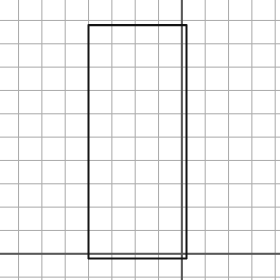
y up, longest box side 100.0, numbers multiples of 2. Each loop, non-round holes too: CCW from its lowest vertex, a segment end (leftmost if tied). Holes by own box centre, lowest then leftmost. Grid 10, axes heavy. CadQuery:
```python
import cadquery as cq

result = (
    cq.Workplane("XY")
    .moveTo(-40.0, -2.0)
    .lineTo(2.0, -2.0)
    .lineTo(2.0, 98.0)
    .lineTo(-40.0, 98.0)
    .close()
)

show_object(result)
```